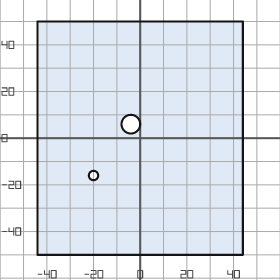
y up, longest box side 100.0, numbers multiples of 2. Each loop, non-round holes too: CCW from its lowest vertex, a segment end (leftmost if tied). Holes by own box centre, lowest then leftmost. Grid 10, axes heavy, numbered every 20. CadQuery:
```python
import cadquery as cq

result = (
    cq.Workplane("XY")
    .moveTo(-44.0, -50.0)
    .lineTo(44.0, -50.0)
    .lineTo(44.0, 50.0)
    .lineTo(-44.0, 50.0)
    .close()
    .moveTo(-20.0, -16.0)
    .circle(2.0)
    .moveTo(-4.0, 6.0)
    .circle(4.0)
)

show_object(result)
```